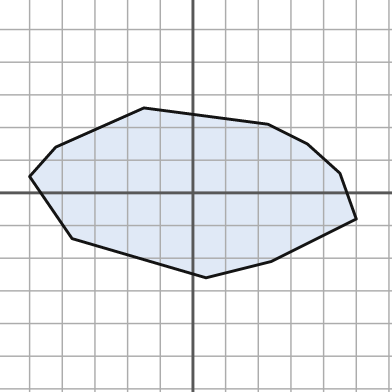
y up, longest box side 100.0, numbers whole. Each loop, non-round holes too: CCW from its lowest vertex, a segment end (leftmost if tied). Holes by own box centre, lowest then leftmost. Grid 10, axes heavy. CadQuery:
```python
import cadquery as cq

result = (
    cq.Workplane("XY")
    .moveTo(4.0, -26.0)
    .lineTo(24.0, -21.0)
    .lineTo(50.0, -8.0)
    .lineTo(45.0, 6.0)
    .lineTo(35.0, 15.0)
    .lineTo(23.0, 21.0)
    .lineTo(-15.0, 26.0)
    .lineTo(-42.0, 14.0)
    .lineTo(-50.0, 5.0)
    .lineTo(-37.0, -14.0)
    .close()
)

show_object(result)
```